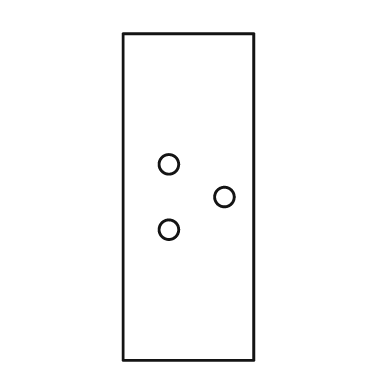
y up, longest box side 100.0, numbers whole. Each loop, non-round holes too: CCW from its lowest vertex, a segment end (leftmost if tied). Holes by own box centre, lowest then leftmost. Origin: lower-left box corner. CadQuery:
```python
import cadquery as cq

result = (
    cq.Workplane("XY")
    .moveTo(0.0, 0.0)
    .lineTo(40.0, 0.0)
    .lineTo(40.0, 100.0)
    .lineTo(0.0, 100.0)
    .close()
    .moveTo(14.0, 40.0)
    .circle(3.0)
    .moveTo(31.0, 50.0)
    .circle(3.0)
    .moveTo(14.0, 60.0)
    .circle(3.0)
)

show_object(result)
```